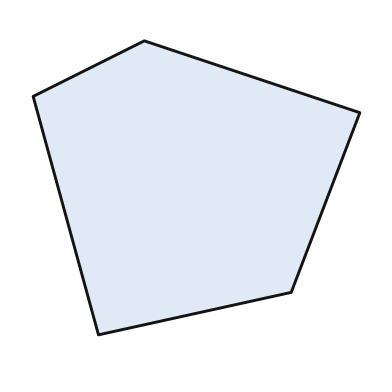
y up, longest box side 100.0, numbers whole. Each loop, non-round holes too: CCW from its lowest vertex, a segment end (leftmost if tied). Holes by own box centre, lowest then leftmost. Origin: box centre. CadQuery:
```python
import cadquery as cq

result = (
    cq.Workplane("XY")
    .moveTo(-30.0, -45.0)
    .lineTo(29.0, -32.0)
    .lineTo(50.0, 23.0)
    .lineTo(-16.0, 45.0)
    .lineTo(-50.0, 28.0)
    .close()
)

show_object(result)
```